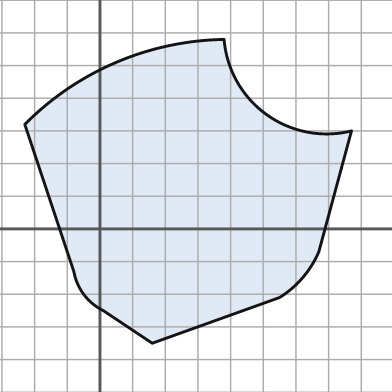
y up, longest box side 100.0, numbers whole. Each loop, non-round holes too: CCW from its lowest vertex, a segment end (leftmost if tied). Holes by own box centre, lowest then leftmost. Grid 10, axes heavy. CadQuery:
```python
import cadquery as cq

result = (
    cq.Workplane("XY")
    .moveTo(16.0, -35.0)
    .lineTo(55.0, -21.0)
    .threePointArc((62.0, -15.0), (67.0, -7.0))
    .lineTo(77.0, 30.0)
    .threePointArc((51.0, 35.0), (38.0, 58.0))
    .threePointArc((5.0, 51.0), (-23.0, 32.0))
    .lineTo(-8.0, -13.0)
    .threePointArc((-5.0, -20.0), (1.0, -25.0))
    .close()
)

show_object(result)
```